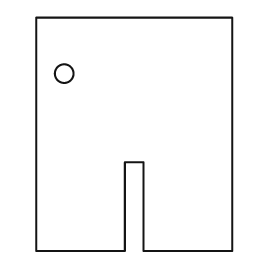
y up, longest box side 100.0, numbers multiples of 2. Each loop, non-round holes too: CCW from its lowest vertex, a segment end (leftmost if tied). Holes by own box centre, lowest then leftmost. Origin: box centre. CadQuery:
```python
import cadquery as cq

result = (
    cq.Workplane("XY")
    .moveTo(-42.0, -50.0)
    .lineTo(-4.0, -50.0)
    .lineTo(-4.0, -12.0)
    .lineTo(4.0, -12.0)
    .lineTo(4.0, -50.0)
    .lineTo(42.0, -50.0)
    .lineTo(42.0, 50.0)
    .lineTo(-42.0, 50.0)
    .close()
    .moveTo(-30.0, 26.0)
    .circle(4.0)
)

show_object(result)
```